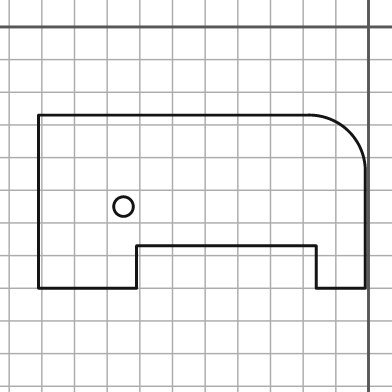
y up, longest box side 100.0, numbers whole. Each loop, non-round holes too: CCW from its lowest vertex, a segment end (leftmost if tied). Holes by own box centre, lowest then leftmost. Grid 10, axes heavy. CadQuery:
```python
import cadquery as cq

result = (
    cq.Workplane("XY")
    .moveTo(-101.0, -80.0)
    .lineTo(-71.0, -80.0)
    .lineTo(-71.0, -67.0)
    .lineTo(-16.0, -67.0)
    .lineTo(-16.0, -80.0)
    .lineTo(-1.0, -80.0)
    .lineTo(-1.0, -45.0)
    .threePointArc((-6.0, -32.0), (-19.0, -27.0))
    .lineTo(-101.0, -27.0)
    .close()
    .moveTo(-75.0, -55.0)
    .circle(3.0)
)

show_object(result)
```